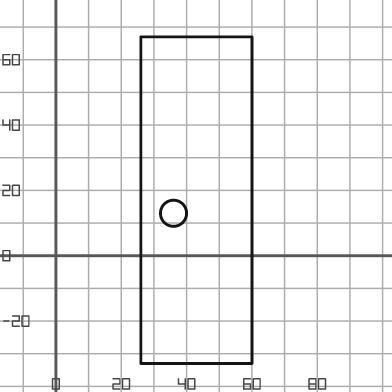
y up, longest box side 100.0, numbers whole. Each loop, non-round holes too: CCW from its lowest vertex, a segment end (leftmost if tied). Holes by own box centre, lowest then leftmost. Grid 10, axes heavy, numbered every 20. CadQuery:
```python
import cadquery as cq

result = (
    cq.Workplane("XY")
    .moveTo(26.0, -33.0)
    .lineTo(60.0, -33.0)
    .lineTo(60.0, 67.0)
    .lineTo(26.0, 67.0)
    .close()
    .moveTo(36.0, 13.0)
    .circle(4.0)
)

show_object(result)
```